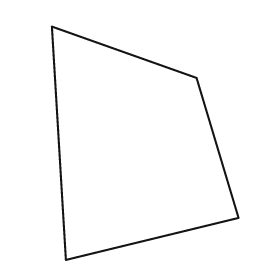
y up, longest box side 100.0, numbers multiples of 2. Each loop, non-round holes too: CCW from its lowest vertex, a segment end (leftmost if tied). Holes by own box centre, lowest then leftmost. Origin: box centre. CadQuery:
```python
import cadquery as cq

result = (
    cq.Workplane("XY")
    .moveTo(-34.0, -50.0)
    .lineTo(40.0, -32.0)
    .lineTo(22.0, 28.0)
    .lineTo(-40.0, 50.0)
    .close()
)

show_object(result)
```